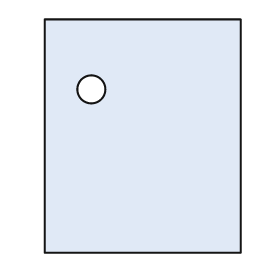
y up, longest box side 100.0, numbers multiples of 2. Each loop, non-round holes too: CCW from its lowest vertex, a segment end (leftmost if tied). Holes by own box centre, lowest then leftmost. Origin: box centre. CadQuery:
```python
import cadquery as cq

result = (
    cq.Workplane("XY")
    .moveTo(-42.0, -50.0)
    .lineTo(42.0, -50.0)
    .lineTo(42.0, 50.0)
    .lineTo(-42.0, 50.0)
    .close()
    .moveTo(-22.0, 20.0)
    .circle(6.0)
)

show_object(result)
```